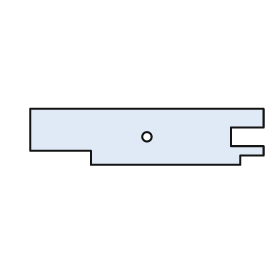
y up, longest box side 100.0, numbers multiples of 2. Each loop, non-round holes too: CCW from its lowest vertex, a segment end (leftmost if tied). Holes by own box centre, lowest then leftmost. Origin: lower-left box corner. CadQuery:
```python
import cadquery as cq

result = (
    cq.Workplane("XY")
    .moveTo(26.0, 0.0)
    .lineTo(90.0, 0.0)
    .lineTo(90.0, 4.0)
    .lineTo(100.0, 4.0)
    .lineTo(100.0, 8.0)
    .lineTo(86.0, 8.0)
    .lineTo(86.0, 16.0)
    .lineTo(100.0, 16.0)
    .lineTo(100.0, 24.0)
    .lineTo(0.0, 24.0)
    .lineTo(0.0, 6.0)
    .lineTo(26.0, 6.0)
    .close()
    .moveTo(50.0, 12.0)
    .circle(2.0)
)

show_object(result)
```